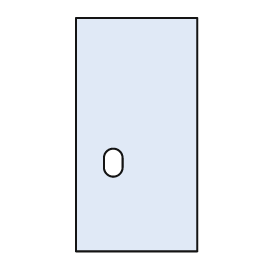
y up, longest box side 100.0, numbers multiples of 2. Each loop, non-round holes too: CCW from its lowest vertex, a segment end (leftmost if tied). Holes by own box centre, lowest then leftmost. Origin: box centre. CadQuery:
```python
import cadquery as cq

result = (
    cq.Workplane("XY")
    .moveTo(-26.0, -50.0)
    .lineTo(26.0, -50.0)
    .lineTo(26.0, 50.0)
    .lineTo(-26.0, 50.0)
    .close()
    .moveTo(-14.0, -14.0)
    .threePointArc((-10.0, -18.0), (-6.0, -14.0))
    .lineTo(-6.0, -10.0)
    .threePointArc((-10.0, -6.0), (-14.0, -10.0))
    .close()
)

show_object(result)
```